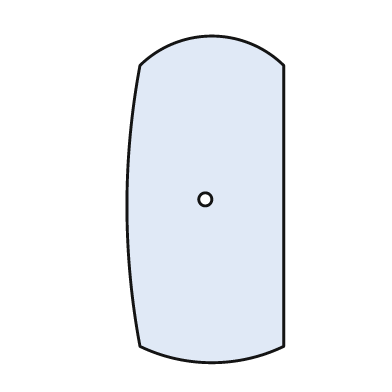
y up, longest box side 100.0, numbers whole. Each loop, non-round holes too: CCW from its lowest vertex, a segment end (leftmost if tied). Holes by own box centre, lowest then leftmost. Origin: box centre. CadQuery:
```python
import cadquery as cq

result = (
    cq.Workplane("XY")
    .moveTo(-20.0, -45.0)
    .threePointArc((2.0, -50.0), (24.0, -45.0))
    .lineTo(24.0, 41.0)
    .threePointArc((2.0, 50.0), (-20.0, 41.0))
    .threePointArc((-24.0, -2.0), (-20.0, -45.0))
    .close()
    .moveTo(0.0, 0.0)
    .circle(2.0)
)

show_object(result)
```